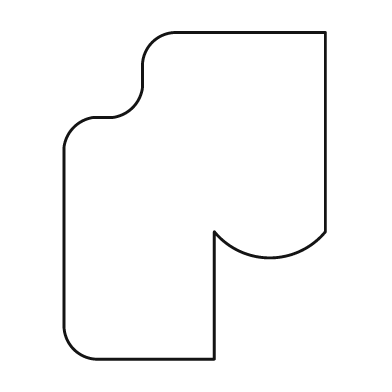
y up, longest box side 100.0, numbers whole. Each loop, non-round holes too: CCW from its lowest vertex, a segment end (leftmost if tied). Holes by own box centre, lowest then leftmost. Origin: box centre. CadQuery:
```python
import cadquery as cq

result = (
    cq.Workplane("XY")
    .moveTo(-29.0, -50.0)
    .lineTo(6.0, -50.0)
    .lineTo(6.0, -11.0)
    .threePointArc((23.0, -19.0), (40.0, -11.0))
    .lineTo(40.0, 50.0)
    .lineTo(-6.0, 50.0)
    .threePointArc((-13.0, 47.0), (-16.0, 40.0))
    .lineTo(-16.0, 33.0)
    .threePointArc((-19.0, 27.0), (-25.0, 24.0))
    .lineTo(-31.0, 24.0)
    .threePointArc((-37.0, 21.0), (-40.0, 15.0))
    .lineTo(-40.0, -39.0)
    .threePointArc((-37.0, -47.0), (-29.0, -50.0))
    .close()
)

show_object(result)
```